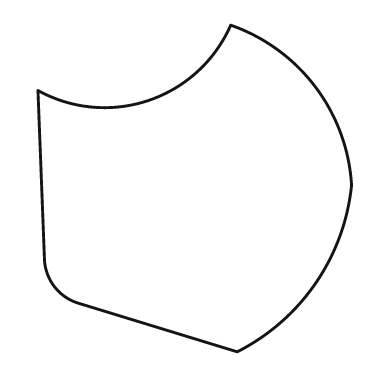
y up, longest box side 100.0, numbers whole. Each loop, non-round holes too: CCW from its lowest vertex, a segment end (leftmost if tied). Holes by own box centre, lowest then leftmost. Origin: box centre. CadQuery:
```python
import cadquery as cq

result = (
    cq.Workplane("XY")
    .moveTo(13.0, -50.0)
    .threePointArc((37.0, -29.0), (48.0, 1.0))
    .threePointArc((37.0, 31.0), (11.0, 50.0))
    .threePointArc((-14.0, 27.0), (-48.0, 30.0))
    .lineTo(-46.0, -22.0)
    .threePointArc((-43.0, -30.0), (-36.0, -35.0))
    .close()
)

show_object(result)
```